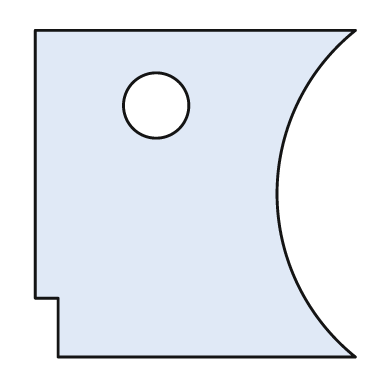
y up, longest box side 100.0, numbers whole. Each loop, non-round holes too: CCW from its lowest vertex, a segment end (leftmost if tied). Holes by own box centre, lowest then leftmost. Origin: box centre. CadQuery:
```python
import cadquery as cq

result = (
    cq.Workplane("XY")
    .moveTo(-42.0, -50.0)
    .lineTo(49.0, -50.0)
    .threePointArc((25.0, 0.0), (49.0, 50.0))
    .lineTo(-49.0, 50.0)
    .lineTo(-49.0, -32.0)
    .lineTo(-42.0, -32.0)
    .close()
    .moveTo(-12.0, 27.0)
    .circle(10.0)
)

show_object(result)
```